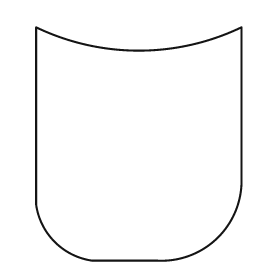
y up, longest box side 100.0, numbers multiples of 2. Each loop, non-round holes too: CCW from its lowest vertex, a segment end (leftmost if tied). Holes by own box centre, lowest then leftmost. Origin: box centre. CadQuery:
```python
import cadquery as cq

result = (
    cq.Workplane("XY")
    .moveTo(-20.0, -50.0)
    .lineTo(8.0, -50.0)
    .threePointArc((34.0, -40.0), (44.0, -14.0))
    .lineTo(44.0, 50.0)
    .threePointArc((0.0, 40.0), (-44.0, 50.0))
    .lineTo(-44.0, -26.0)
    .threePointArc((-36.0, -42.0), (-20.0, -50.0))
    .close()
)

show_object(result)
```